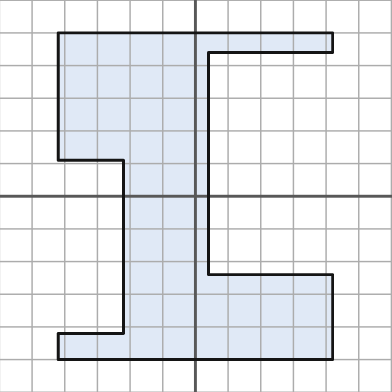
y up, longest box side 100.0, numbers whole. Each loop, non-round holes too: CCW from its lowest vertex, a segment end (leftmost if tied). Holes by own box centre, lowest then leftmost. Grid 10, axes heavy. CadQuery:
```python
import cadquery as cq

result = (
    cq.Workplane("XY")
    .moveTo(-42.0, -50.0)
    .lineTo(42.0, -50.0)
    .lineTo(42.0, -24.0)
    .lineTo(4.0, -24.0)
    .lineTo(4.0, 44.0)
    .lineTo(42.0, 44.0)
    .lineTo(42.0, 50.0)
    .lineTo(-42.0, 50.0)
    .lineTo(-42.0, 11.0)
    .lineTo(-22.0, 11.0)
    .lineTo(-22.0, -42.0)
    .lineTo(-42.0, -42.0)
    .close()
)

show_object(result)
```